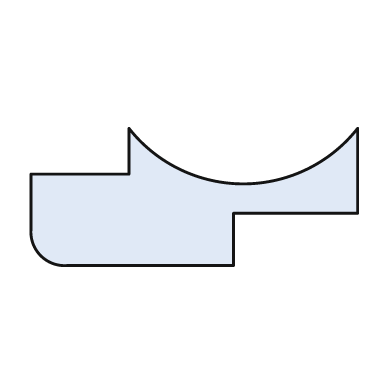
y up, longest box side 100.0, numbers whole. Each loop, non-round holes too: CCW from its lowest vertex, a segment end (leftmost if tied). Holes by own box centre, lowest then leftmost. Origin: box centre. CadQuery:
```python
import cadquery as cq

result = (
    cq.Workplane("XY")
    .moveTo(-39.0, -21.0)
    .lineTo(12.0, -21.0)
    .lineTo(12.0, -5.0)
    .lineTo(50.0, -5.0)
    .lineTo(50.0, 21.0)
    .threePointArc((15.0, 4.0), (-20.0, 21.0))
    .lineTo(-20.0, 7.0)
    .lineTo(-50.0, 7.0)
    .lineTo(-50.0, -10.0)
    .threePointArc((-47.0, -18.0), (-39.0, -21.0))
    .close()
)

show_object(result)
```